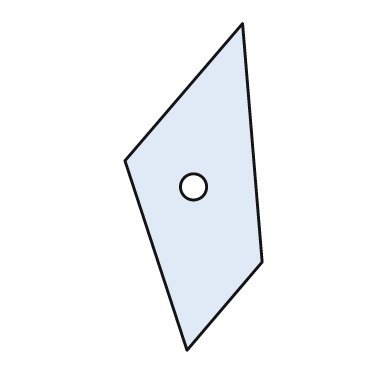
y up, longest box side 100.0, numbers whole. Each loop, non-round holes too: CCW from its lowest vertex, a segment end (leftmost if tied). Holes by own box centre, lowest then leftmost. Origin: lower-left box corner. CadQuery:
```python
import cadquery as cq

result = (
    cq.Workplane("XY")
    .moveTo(19.0, 0.0)
    .lineTo(42.0, 27.0)
    .lineTo(36.0, 100.0)
    .lineTo(0.0, 58.0)
    .close()
    .moveTo(21.0, 50.0)
    .circle(4.0)
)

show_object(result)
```